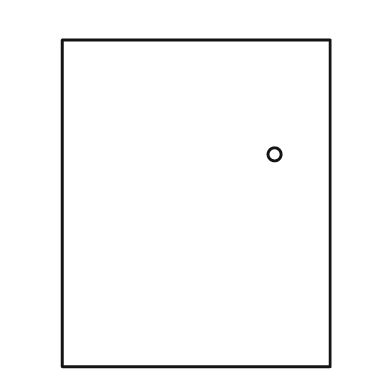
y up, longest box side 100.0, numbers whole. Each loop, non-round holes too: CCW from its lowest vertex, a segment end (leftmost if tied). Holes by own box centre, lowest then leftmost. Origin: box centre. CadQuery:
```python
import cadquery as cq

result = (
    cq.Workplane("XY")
    .moveTo(-41.0, -50.0)
    .lineTo(41.0, -50.0)
    .lineTo(41.0, 50.0)
    .lineTo(-41.0, 50.0)
    .close()
    .moveTo(24.0, 15.0)
    .circle(2.0)
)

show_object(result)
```